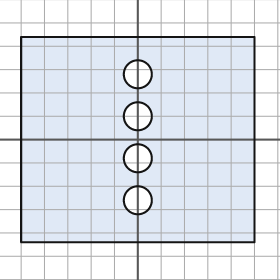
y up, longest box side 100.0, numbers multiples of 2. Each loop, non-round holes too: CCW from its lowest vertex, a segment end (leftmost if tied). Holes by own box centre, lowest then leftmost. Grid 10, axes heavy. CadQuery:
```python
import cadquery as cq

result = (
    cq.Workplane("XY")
    .moveTo(-50.0, -44.0)
    .lineTo(50.0, -44.0)
    .lineTo(50.0, 44.0)
    .lineTo(-50.0, 44.0)
    .close()
    .moveTo(0.0, -26.0)
    .circle(6.0)
    .moveTo(0.0, -8.0)
    .circle(6.0)
    .moveTo(0.0, 10.0)
    .circle(6.0)
    .moveTo(0.0, 28.0)
    .circle(6.0)
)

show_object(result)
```